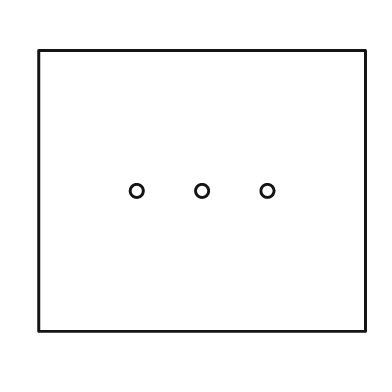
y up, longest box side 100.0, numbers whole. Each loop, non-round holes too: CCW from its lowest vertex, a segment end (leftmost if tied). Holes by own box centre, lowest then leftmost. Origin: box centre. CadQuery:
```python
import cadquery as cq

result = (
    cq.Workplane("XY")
    .moveTo(-50.0, -43.0)
    .lineTo(50.0, -43.0)
    .lineTo(50.0, 43.0)
    .lineTo(-50.0, 43.0)
    .close()
    .moveTo(-20.0, 0.0)
    .circle(2.0)
    .moveTo(0.0, 0.0)
    .circle(2.0)
    .moveTo(20.0, 0.0)
    .circle(2.0)
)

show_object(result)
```